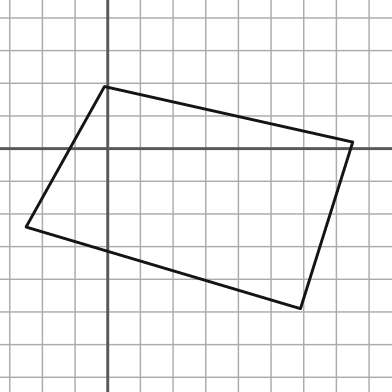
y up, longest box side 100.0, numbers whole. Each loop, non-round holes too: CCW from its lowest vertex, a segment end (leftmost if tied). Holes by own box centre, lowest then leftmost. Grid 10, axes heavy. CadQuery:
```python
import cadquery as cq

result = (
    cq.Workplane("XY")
    .moveTo(59.0, -49.0)
    .lineTo(75.0, 2.0)
    .lineTo(-1.0, 19.0)
    .lineTo(-25.0, -24.0)
    .close()
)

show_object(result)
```